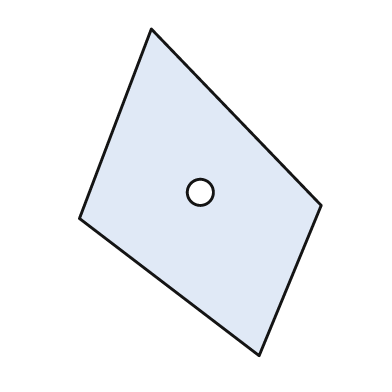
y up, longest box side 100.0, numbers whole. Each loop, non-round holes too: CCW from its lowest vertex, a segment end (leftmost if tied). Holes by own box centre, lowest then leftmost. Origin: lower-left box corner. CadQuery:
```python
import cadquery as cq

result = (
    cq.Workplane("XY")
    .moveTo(55.0, 0.0)
    .lineTo(74.0, 46.0)
    .lineTo(22.0, 100.0)
    .lineTo(0.0, 42.0)
    .close()
    .moveTo(37.0, 50.0)
    .circle(4.0)
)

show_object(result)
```